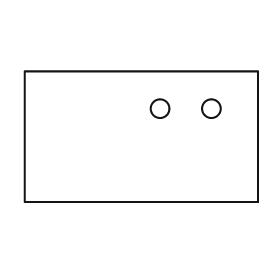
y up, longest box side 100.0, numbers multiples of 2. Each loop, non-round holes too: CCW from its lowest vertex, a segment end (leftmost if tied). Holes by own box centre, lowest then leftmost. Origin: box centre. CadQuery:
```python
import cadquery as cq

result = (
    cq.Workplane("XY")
    .moveTo(-50.0, -28.0)
    .lineTo(50.0, -28.0)
    .lineTo(50.0, 28.0)
    .lineTo(-50.0, 28.0)
    .close()
    .moveTo(8.0, 12.0)
    .circle(4.0)
    .moveTo(30.0, 12.0)
    .circle(4.0)
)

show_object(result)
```